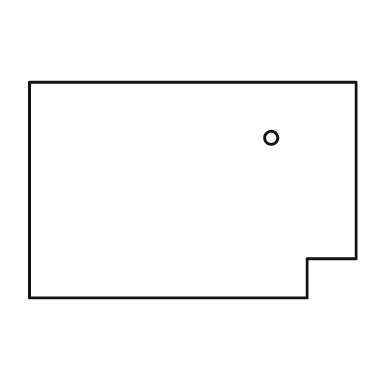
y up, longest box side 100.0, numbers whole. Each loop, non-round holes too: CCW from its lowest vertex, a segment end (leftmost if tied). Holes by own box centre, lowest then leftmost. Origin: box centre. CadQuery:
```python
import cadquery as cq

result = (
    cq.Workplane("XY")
    .moveTo(-50.0, -33.0)
    .lineTo(35.0, -33.0)
    .lineTo(35.0, -21.0)
    .lineTo(50.0, -21.0)
    .lineTo(50.0, 33.0)
    .lineTo(-50.0, 33.0)
    .close()
    .moveTo(24.0, 16.0)
    .circle(2.0)
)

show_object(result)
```